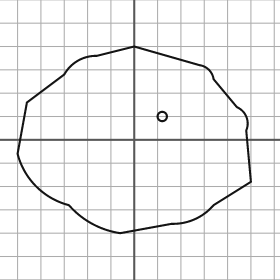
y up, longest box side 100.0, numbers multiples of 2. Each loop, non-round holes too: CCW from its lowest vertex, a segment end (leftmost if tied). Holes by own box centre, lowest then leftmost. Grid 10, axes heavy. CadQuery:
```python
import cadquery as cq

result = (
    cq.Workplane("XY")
    .moveTo(-6.0, -40.0)
    .lineTo(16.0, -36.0)
    .threePointArc((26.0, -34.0), (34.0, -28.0))
    .lineTo(50.0, -18.0)
    .lineTo(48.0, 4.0)
    .threePointArc((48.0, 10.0), (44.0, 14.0))
    .lineTo(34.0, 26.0)
    .threePointArc((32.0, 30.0), (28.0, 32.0))
    .lineTo(0.0, 40.0)
    .lineTo(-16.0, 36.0)
    .threePointArc((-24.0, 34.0), (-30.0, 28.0))
    .lineTo(-46.0, 16.0)
    .lineTo(-50.0, -6.0)
    .threePointArc((-42.0, -20.0), (-28.0, -28.0))
    .threePointArc((-18.0, -36.0), (-6.0, -40.0))
    .close()
    .moveTo(12.0, 10.0)
    .circle(2.0)
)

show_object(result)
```